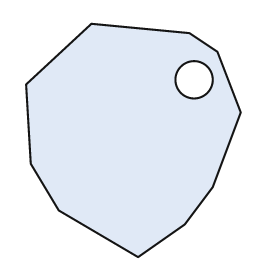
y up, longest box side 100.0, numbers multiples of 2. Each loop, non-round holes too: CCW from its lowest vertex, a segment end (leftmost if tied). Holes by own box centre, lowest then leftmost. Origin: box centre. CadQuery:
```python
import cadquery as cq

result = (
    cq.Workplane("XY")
    .moveTo(2.0, -50.0)
    .lineTo(22.0, -36.0)
    .lineTo(34.0, -20.0)
    .lineTo(46.0, 12.0)
    .lineTo(36.0, 38.0)
    .lineTo(24.0, 46.0)
    .lineTo(-18.0, 50.0)
    .lineTo(-46.0, 24.0)
    .lineTo(-44.0, -10.0)
    .lineTo(-32.0, -30.0)
    .close()
    .moveTo(26.0, 26.0)
    .circle(8.0)
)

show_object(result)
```